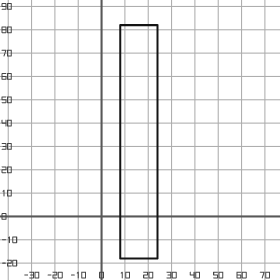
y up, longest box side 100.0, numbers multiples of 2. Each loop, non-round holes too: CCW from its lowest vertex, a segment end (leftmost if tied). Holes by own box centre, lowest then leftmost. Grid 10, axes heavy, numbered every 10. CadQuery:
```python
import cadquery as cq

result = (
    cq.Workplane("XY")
    .moveTo(8.0, -18.0)
    .lineTo(24.0, -18.0)
    .lineTo(24.0, 82.0)
    .lineTo(8.0, 82.0)
    .close()
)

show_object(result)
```